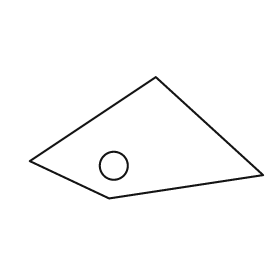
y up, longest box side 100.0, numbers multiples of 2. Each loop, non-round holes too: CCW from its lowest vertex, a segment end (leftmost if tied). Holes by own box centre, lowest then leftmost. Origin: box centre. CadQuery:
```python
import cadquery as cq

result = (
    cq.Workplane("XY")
    .moveTo(-16.0, -26.0)
    .lineTo(50.0, -16.0)
    .lineTo(4.0, 26.0)
    .lineTo(-50.0, -10.0)
    .close()
    .moveTo(-14.0, -12.0)
    .circle(6.0)
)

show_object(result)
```